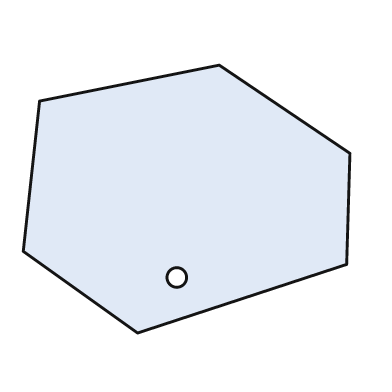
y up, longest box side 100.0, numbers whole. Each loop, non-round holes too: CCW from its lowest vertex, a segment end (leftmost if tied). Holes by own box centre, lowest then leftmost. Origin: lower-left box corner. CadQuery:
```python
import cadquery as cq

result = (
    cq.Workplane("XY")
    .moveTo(35.0, 0.0)
    .lineTo(99.0, 21.0)
    .lineTo(100.0, 55.0)
    .lineTo(60.0, 82.0)
    .lineTo(5.0, 71.0)
    .lineTo(0.0, 25.0)
    .close()
    .moveTo(47.0, 17.0)
    .circle(3.0)
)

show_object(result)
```